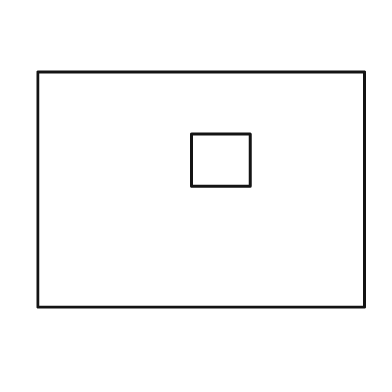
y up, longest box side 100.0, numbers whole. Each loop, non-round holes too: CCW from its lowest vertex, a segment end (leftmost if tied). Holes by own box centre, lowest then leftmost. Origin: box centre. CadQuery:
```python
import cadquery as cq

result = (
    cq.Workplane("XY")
    .moveTo(-50.0, -36.0)
    .lineTo(50.0, -36.0)
    .lineTo(50.0, 36.0)
    .lineTo(-50.0, 36.0)
    .close()
    .moveTo(-3.0, 1.0)
    .lineTo(15.0, 1.0)
    .lineTo(15.0, 17.0)
    .lineTo(-3.0, 17.0)
    .close()
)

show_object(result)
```